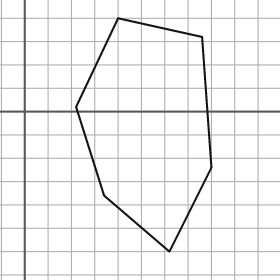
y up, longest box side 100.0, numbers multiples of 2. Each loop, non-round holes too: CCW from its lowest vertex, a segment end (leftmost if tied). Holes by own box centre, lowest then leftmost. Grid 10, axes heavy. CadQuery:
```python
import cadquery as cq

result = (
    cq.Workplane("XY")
    .moveTo(62.0, -60.0)
    .lineTo(80.0, -24.0)
    .lineTo(76.0, 32.0)
    .lineTo(40.0, 40.0)
    .lineTo(22.0, 2.0)
    .lineTo(34.0, -36.0)
    .close()
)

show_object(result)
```